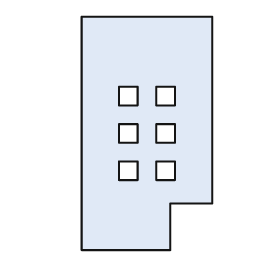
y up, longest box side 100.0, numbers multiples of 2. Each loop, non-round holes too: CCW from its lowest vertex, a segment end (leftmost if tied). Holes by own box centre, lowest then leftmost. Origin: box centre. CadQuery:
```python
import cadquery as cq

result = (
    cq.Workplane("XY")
    .moveTo(-28.0, -50.0)
    .lineTo(10.0, -50.0)
    .lineTo(10.0, -30.0)
    .lineTo(28.0, -30.0)
    .lineTo(28.0, 50.0)
    .lineTo(-28.0, 50.0)
    .close()
    .moveTo(-12.0, -20.0)
    .lineTo(-4.0, -20.0)
    .lineTo(-4.0, -12.0)
    .lineTo(-12.0, -12.0)
    .close()
    .moveTo(4.0, -20.0)
    .lineTo(12.0, -20.0)
    .lineTo(12.0, -12.0)
    .lineTo(4.0, -12.0)
    .close()
    .moveTo(-12.0, -4.0)
    .lineTo(-4.0, -4.0)
    .lineTo(-4.0, 4.0)
    .lineTo(-12.0, 4.0)
    .close()
    .moveTo(4.0, -4.0)
    .lineTo(12.0, -4.0)
    .lineTo(12.0, 4.0)
    .lineTo(4.0, 4.0)
    .close()
    .moveTo(-12.0, 12.0)
    .lineTo(-4.0, 12.0)
    .lineTo(-4.0, 20.0)
    .lineTo(-12.0, 20.0)
    .close()
    .moveTo(4.0, 12.0)
    .lineTo(12.0, 12.0)
    .lineTo(12.0, 20.0)
    .lineTo(4.0, 20.0)
    .close()
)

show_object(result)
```